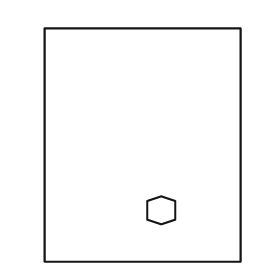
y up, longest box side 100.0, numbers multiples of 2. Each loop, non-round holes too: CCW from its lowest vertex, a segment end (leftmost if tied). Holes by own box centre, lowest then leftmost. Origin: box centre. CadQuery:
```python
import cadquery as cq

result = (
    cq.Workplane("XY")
    .moveTo(-42.0, -50.0)
    .lineTo(42.0, -50.0)
    .lineTo(42.0, 50.0)
    .lineTo(-42.0, 50.0)
    .close()
    .moveTo(8.0, -34.0)
    .lineTo(14.0, -32.0)
    .lineTo(14.0, -24.0)
    .lineTo(8.0, -22.0)
    .lineTo(2.0, -24.0)
    .lineTo(2.0, -32.0)
    .close()
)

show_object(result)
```